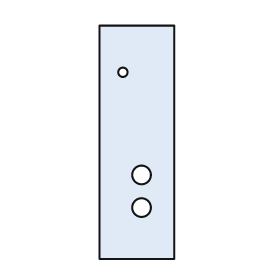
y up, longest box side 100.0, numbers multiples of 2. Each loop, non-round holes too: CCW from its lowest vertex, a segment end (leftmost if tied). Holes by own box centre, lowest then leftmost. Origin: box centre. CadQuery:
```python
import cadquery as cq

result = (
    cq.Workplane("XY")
    .moveTo(-16.0, -50.0)
    .lineTo(16.0, -50.0)
    .lineTo(16.0, 50.0)
    .lineTo(-16.0, 50.0)
    .close()
    .moveTo(2.0, -28.0)
    .circle(4.0)
    .moveTo(2.0, -14.0)
    .circle(4.0)
    .moveTo(-6.0, 30.0)
    .circle(2.0)
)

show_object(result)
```